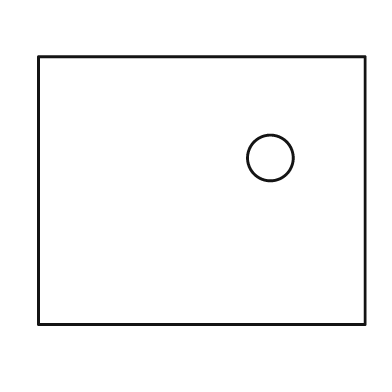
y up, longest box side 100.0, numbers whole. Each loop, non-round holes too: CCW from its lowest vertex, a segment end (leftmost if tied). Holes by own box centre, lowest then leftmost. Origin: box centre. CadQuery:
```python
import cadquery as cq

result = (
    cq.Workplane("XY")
    .moveTo(-50.0, -41.0)
    .lineTo(50.0, -41.0)
    .lineTo(50.0, 41.0)
    .lineTo(-50.0, 41.0)
    .close()
    .moveTo(21.0, 10.0)
    .circle(7.0)
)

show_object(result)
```